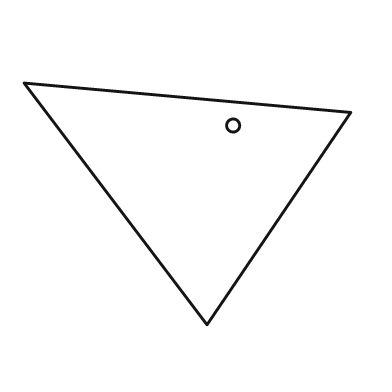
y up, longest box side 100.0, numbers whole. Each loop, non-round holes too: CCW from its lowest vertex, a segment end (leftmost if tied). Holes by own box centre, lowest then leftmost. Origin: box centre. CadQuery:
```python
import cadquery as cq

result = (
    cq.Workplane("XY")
    .moveTo(6.0, -37.0)
    .lineTo(50.0, 28.0)
    .lineTo(-50.0, 37.0)
    .close()
    .moveTo(14.0, 24.0)
    .circle(2.0)
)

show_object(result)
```